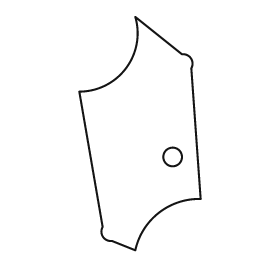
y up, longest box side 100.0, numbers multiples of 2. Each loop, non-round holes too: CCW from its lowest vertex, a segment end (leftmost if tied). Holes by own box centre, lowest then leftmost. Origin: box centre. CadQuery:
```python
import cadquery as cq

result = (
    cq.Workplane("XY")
    .moveTo(-2.0, -50.0)
    .threePointArc((8.0, -34.0), (26.0, -28.0))
    .lineTo(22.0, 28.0)
    .threePointArc((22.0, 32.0), (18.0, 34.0))
    .lineTo(-2.0, 50.0)
    .threePointArc((-6.0, 28.0), (-26.0, 18.0))
    .lineTo(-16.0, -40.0)
    .threePointArc((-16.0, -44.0), (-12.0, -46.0))
    .close()
    .moveTo(14.0, -10.0)
    .circle(4.0)
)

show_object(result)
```